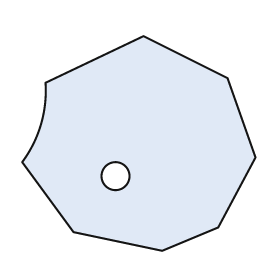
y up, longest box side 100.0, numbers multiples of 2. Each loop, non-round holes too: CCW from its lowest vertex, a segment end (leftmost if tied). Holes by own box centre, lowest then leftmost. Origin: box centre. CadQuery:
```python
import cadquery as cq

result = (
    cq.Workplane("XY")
    .moveTo(10.0, -46.0)
    .lineTo(34.0, -36.0)
    .lineTo(50.0, -6.0)
    .lineTo(38.0, 28.0)
    .lineTo(2.0, 46.0)
    .lineTo(-40.0, 26.0)
    .threePointArc((-42.0, 8.0), (-50.0, -8.0))
    .lineTo(-28.0, -38.0)
    .close()
    .moveTo(-10.0, -14.0)
    .circle(6.0)
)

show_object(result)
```